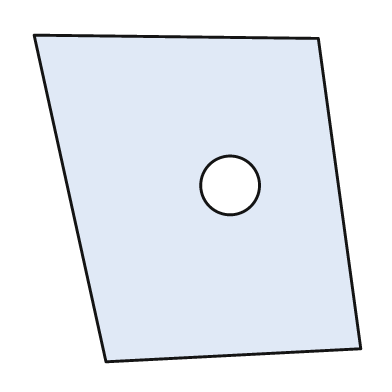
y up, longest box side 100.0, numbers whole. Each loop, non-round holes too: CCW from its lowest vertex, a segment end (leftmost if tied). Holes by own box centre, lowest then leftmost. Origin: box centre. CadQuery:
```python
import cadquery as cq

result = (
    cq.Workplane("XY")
    .moveTo(-28.0, -50.0)
    .lineTo(50.0, -46.0)
    .lineTo(37.0, 49.0)
    .lineTo(-50.0, 50.0)
    .close()
    .moveTo(10.0, 4.0)
    .circle(9.0)
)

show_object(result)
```